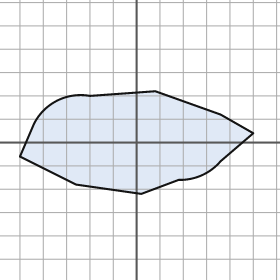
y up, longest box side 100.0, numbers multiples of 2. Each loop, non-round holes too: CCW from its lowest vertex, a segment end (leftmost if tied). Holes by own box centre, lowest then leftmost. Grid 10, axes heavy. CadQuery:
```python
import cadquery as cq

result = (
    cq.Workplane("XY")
    .moveTo(2.0, -22.0)
    .lineTo(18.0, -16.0)
    .threePointArc((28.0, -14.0), (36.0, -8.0))
    .lineTo(50.0, 4.0)
    .lineTo(36.0, 12.0)
    .lineTo(8.0, 22.0)
    .lineTo(-20.0, 20.0)
    .threePointArc((-34.0, 18.0), (-44.0, 8.0))
    .lineTo(-50.0, -6.0)
    .lineTo(-26.0, -18.0)
    .close()
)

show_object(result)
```